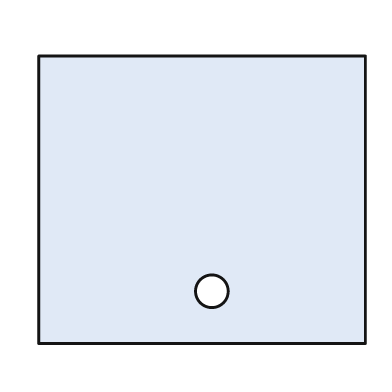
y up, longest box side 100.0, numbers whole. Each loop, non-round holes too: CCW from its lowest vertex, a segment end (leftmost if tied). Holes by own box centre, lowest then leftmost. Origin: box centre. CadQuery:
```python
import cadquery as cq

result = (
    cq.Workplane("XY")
    .moveTo(-50.0, -44.0)
    .lineTo(50.0, -44.0)
    .lineTo(50.0, 44.0)
    .lineTo(-50.0, 44.0)
    .close()
    .moveTo(3.0, -28.0)
    .circle(5.0)
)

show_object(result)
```